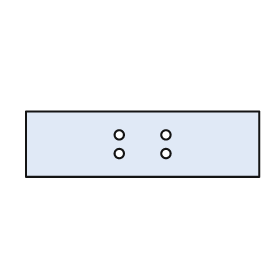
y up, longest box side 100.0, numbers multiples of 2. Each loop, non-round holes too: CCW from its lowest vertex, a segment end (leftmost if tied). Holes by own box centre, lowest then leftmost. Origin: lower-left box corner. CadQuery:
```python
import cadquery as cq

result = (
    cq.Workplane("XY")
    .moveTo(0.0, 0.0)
    .lineTo(100.0, 0.0)
    .lineTo(100.0, 28.0)
    .lineTo(0.0, 28.0)
    .close()
    .moveTo(40.0, 10.0)
    .circle(2.0)
    .moveTo(60.0, 10.0)
    .circle(2.0)
    .moveTo(40.0, 18.0)
    .circle(2.0)
    .moveTo(60.0, 18.0)
    .circle(2.0)
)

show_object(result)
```